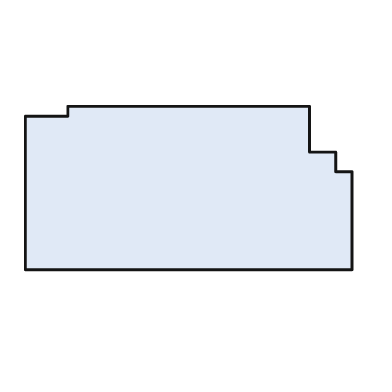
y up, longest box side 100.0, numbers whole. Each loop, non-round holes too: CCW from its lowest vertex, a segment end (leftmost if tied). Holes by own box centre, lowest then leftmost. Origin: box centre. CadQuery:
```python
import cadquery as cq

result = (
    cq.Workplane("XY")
    .moveTo(-50.0, -25.0)
    .lineTo(50.0, -25.0)
    .lineTo(50.0, 5.0)
    .lineTo(45.0, 5.0)
    .lineTo(45.0, 11.0)
    .lineTo(37.0, 11.0)
    .lineTo(37.0, 25.0)
    .lineTo(-37.0, 25.0)
    .lineTo(-37.0, 22.0)
    .lineTo(-50.0, 22.0)
    .close()
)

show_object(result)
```